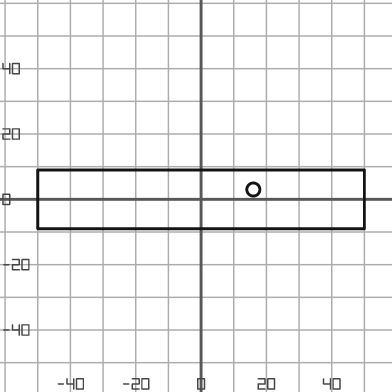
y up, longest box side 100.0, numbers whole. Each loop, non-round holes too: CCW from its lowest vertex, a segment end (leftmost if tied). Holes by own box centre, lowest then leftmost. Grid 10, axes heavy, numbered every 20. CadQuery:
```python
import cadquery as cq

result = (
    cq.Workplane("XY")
    .moveTo(-50.0, -9.0)
    .lineTo(50.0, -9.0)
    .lineTo(50.0, 9.0)
    .lineTo(-50.0, 9.0)
    .close()
    .moveTo(16.0, 3.0)
    .circle(2.0)
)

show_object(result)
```